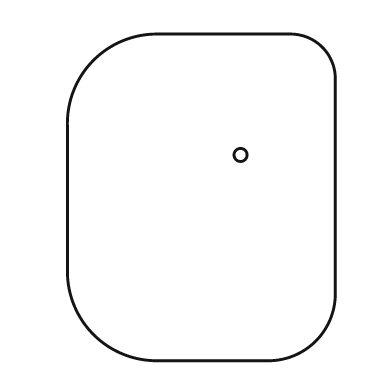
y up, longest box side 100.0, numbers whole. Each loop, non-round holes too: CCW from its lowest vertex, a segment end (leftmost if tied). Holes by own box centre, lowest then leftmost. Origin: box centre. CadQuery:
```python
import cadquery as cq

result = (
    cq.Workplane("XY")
    .moveTo(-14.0, -50.0)
    .lineTo(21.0, -50.0)
    .threePointArc((35.0, -44.0), (41.0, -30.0))
    .lineTo(41.0, 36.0)
    .threePointArc((37.0, 46.0), (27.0, 50.0))
    .lineTo(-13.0, 50.0)
    .threePointArc((-33.0, 42.0), (-41.0, 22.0))
    .lineTo(-41.0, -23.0)
    .threePointArc((-33.0, -42.0), (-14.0, -50.0))
    .close()
    .moveTo(12.0, 13.0)
    .circle(2.0)
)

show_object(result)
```